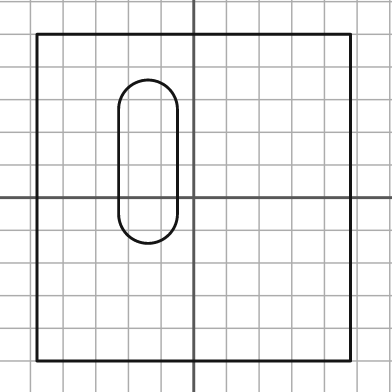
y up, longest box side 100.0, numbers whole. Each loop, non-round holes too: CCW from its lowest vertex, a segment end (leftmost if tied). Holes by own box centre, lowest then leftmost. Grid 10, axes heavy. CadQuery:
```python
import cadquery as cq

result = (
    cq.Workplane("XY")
    .moveTo(-48.0, -50.0)
    .lineTo(48.0, -50.0)
    .lineTo(48.0, 50.0)
    .lineTo(-48.0, 50.0)
    .close()
    .moveTo(-23.0, -5.0)
    .threePointArc((-14.0, -14.0), (-5.0, -5.0))
    .lineTo(-5.0, 27.0)
    .threePointArc((-14.0, 36.0), (-23.0, 27.0))
    .close()
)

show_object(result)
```